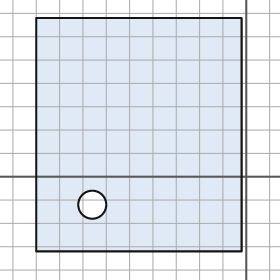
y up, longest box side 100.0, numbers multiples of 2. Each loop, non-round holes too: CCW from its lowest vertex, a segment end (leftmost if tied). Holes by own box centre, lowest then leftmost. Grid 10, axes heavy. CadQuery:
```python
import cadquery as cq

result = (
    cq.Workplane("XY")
    .moveTo(-90.0, -32.0)
    .lineTo(-2.0, -32.0)
    .lineTo(-2.0, 68.0)
    .lineTo(-90.0, 68.0)
    .close()
    .moveTo(-66.0, -12.0)
    .circle(6.0)
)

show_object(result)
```